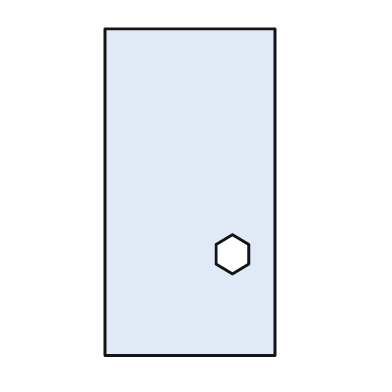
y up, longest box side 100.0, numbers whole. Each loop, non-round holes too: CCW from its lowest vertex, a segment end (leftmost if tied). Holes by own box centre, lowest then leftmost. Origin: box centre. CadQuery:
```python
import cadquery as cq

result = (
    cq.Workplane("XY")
    .moveTo(-26.0, -50.0)
    .lineTo(26.0, -50.0)
    .lineTo(26.0, 50.0)
    .lineTo(-26.0, 50.0)
    .close()
    .moveTo(13.0, -25.0)
    .lineTo(18.0, -22.0)
    .lineTo(18.0, -16.0)
    .lineTo(13.0, -13.0)
    .lineTo(8.0, -16.0)
    .lineTo(8.0, -22.0)
    .close()
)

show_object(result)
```